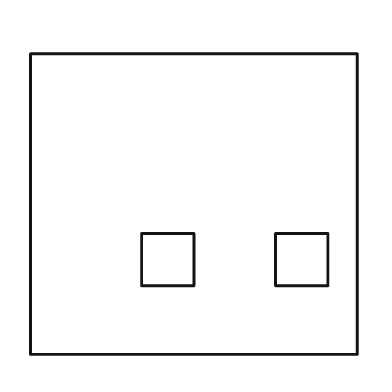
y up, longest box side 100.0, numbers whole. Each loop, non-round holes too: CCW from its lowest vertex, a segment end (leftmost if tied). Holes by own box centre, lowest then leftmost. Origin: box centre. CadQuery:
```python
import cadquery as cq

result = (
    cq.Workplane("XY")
    .moveTo(-50.0, -46.0)
    .lineTo(50.0, -46.0)
    .lineTo(50.0, 46.0)
    .lineTo(-50.0, 46.0)
    .close()
    .moveTo(-16.0, -25.0)
    .lineTo(0.0, -25.0)
    .lineTo(0.0, -9.0)
    .lineTo(-16.0, -9.0)
    .close()
    .moveTo(25.0, -25.0)
    .lineTo(41.0, -25.0)
    .lineTo(41.0, -9.0)
    .lineTo(25.0, -9.0)
    .close()
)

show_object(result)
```